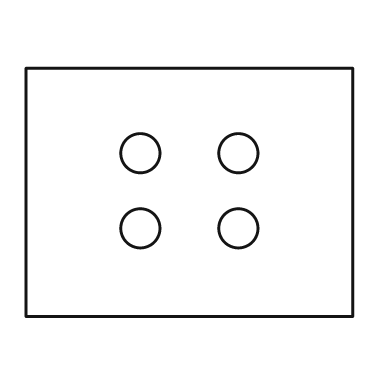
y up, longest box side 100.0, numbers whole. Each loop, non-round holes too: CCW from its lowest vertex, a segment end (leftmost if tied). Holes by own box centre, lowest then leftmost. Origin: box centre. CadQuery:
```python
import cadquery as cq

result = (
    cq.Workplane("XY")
    .moveTo(-50.0, -38.0)
    .lineTo(50.0, -38.0)
    .lineTo(50.0, 38.0)
    .lineTo(-50.0, 38.0)
    .close()
    .moveTo(-15.0, -11.0)
    .circle(6.0)
    .moveTo(15.0, -11.0)
    .circle(6.0)
    .moveTo(-15.0, 12.0)
    .circle(6.0)
    .moveTo(15.0, 12.0)
    .circle(6.0)
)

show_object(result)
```